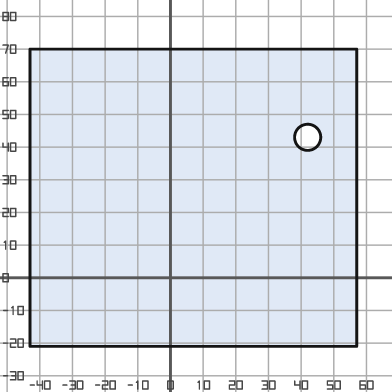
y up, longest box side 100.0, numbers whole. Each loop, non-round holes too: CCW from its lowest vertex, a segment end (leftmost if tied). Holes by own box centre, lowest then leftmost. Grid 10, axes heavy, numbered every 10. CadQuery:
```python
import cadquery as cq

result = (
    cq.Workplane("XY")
    .moveTo(-43.0, -21.0)
    .lineTo(57.0, -21.0)
    .lineTo(57.0, 70.0)
    .lineTo(-43.0, 70.0)
    .close()
    .moveTo(42.0, 43.0)
    .circle(4.0)
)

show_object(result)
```